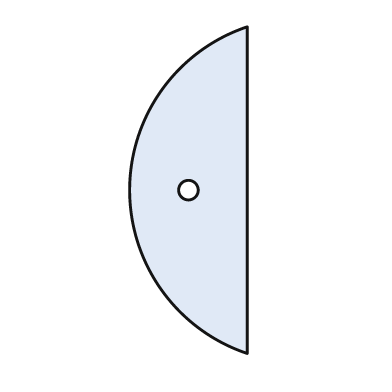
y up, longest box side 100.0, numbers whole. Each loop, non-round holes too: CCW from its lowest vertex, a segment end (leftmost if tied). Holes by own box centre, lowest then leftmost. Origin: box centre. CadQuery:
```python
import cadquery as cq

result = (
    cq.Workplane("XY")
    .moveTo(18.0, -50.0)
    .lineTo(18.0, 50.0)
    .threePointArc((-18.0, 0.0), (18.0, -50.0))
    .close()
    .moveTo(0.0, 0.0)
    .circle(3.0)
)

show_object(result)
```